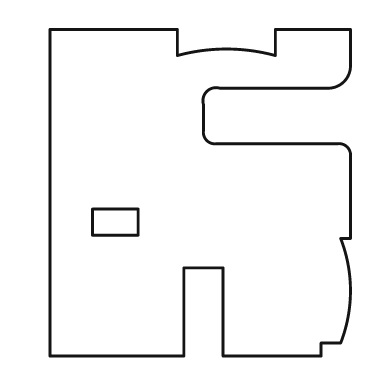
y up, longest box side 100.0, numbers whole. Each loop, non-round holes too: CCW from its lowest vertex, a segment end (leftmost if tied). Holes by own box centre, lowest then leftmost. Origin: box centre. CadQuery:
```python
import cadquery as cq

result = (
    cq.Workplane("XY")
    .moveTo(-46.0, -50.0)
    .lineTo(-5.0, -50.0)
    .lineTo(-5.0, -23.0)
    .lineTo(7.0, -23.0)
    .lineTo(7.0, -50.0)
    .lineTo(37.0, -50.0)
    .lineTo(37.0, -46.0)
    .lineTo(43.0, -46.0)
    .threePointArc((46.0, -30.0), (43.0, -14.0))
    .lineTo(46.0, -14.0)
    .lineTo(46.0, 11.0)
    .threePointArc((45.0, 14.0), (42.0, 15.0))
    .lineTo(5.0, 15.0)
    .threePointArc((2.0, 16.0), (1.0, 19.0))
    .lineTo(1.0, 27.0)
    .threePointArc((2.0, 31.0), (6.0, 32.0))
    .lineTo(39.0, 32.0)
    .threePointArc((44.0, 34.0), (46.0, 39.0))
    .lineTo(46.0, 50.0)
    .lineTo(23.0, 50.0)
    .lineTo(23.0, 42.0)
    .threePointArc((8.0, 44.0), (-7.0, 42.0))
    .lineTo(-7.0, 50.0)
    .lineTo(-46.0, 50.0)
    .close()
    .moveTo(-33.0, -13.0)
    .lineTo(-19.0, -13.0)
    .lineTo(-19.0, -5.0)
    .lineTo(-33.0, -5.0)
    .close()
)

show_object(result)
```